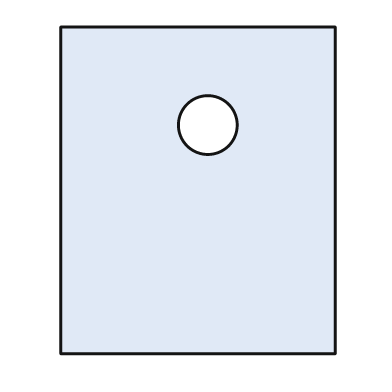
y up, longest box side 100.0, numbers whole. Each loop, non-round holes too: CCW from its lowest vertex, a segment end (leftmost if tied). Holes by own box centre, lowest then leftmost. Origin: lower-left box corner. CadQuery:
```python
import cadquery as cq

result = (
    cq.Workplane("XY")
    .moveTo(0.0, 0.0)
    .lineTo(84.0, 0.0)
    .lineTo(84.0, 100.0)
    .lineTo(0.0, 100.0)
    .close()
    .moveTo(45.0, 70.0)
    .circle(9.0)
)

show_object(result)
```